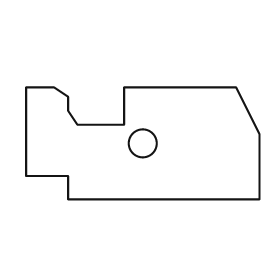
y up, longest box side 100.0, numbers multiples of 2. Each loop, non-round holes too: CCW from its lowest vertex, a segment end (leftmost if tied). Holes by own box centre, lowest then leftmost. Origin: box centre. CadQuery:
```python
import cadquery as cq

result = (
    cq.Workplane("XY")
    .moveTo(-32.0, -24.0)
    .lineTo(50.0, -24.0)
    .lineTo(50.0, 4.0)
    .lineTo(40.0, 24.0)
    .lineTo(-8.0, 24.0)
    .lineTo(-8.0, 8.0)
    .lineTo(-28.0, 8.0)
    .lineTo(-32.0, 14.0)
    .lineTo(-32.0, 20.0)
    .lineTo(-38.0, 24.0)
    .lineTo(-50.0, 24.0)
    .lineTo(-50.0, -14.0)
    .lineTo(-32.0, -14.0)
    .close()
    .moveTo(0.0, 0.0)
    .circle(6.0)
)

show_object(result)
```